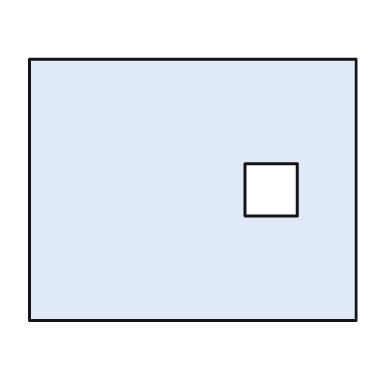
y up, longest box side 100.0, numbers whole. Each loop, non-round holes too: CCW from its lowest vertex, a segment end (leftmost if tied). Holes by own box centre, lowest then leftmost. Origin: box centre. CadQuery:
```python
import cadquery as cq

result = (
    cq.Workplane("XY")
    .moveTo(-50.0, -40.0)
    .lineTo(50.0, -40.0)
    .lineTo(50.0, 40.0)
    .lineTo(-50.0, 40.0)
    .close()
    .moveTo(16.0, -8.0)
    .lineTo(32.0, -8.0)
    .lineTo(32.0, 8.0)
    .lineTo(16.0, 8.0)
    .close()
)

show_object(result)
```